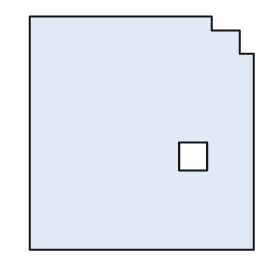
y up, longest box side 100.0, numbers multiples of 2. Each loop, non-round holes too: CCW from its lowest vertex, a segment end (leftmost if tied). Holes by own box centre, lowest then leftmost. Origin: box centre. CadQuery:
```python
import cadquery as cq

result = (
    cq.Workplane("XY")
    .moveTo(-48.0, -50.0)
    .lineTo(48.0, -50.0)
    .lineTo(48.0, 34.0)
    .lineTo(42.0, 34.0)
    .lineTo(42.0, 44.0)
    .lineTo(30.0, 44.0)
    .lineTo(30.0, 50.0)
    .lineTo(-48.0, 50.0)
    .close()
    .moveTo(16.0, -16.0)
    .lineTo(28.0, -16.0)
    .lineTo(28.0, -4.0)
    .lineTo(16.0, -4.0)
    .close()
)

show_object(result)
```